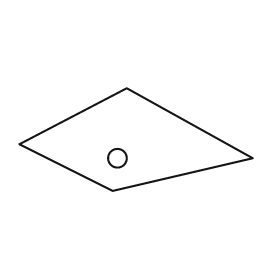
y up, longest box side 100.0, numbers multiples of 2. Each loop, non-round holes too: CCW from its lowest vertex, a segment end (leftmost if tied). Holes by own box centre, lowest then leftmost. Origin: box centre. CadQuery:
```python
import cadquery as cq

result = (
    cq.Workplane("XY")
    .moveTo(-10.0, -22.0)
    .lineTo(50.0, -8.0)
    .lineTo(-4.0, 22.0)
    .lineTo(-50.0, -2.0)
    .close()
    .moveTo(-8.0, -8.0)
    .circle(4.0)
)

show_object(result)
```